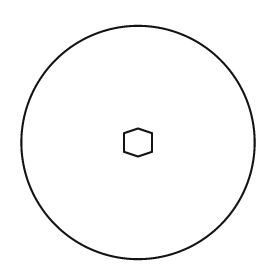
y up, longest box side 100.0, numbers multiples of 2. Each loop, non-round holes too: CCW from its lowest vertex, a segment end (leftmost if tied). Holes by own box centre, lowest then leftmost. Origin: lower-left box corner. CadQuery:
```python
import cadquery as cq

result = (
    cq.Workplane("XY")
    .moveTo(50.0, 50.0)
    .circle(50.0)
    .moveTo(50.0, 44.0)
    .lineTo(56.0, 46.0)
    .lineTo(56.0, 54.0)
    .lineTo(50.0, 56.0)
    .lineTo(44.0, 54.0)
    .lineTo(44.0, 46.0)
    .close()
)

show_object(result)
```